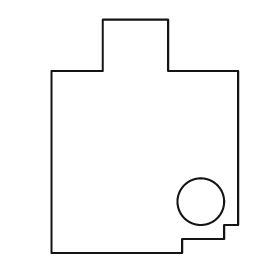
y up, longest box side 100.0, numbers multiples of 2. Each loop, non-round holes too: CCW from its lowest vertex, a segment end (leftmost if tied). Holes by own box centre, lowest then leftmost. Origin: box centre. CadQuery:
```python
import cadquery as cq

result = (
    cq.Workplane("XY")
    .moveTo(-40.0, -50.0)
    .lineTo(16.0, -50.0)
    .lineTo(16.0, -44.0)
    .lineTo(34.0, -44.0)
    .lineTo(34.0, -38.0)
    .lineTo(40.0, -38.0)
    .lineTo(40.0, 28.0)
    .lineTo(10.0, 28.0)
    .lineTo(10.0, 50.0)
    .lineTo(-18.0, 50.0)
    .lineTo(-18.0, 28.0)
    .lineTo(-40.0, 28.0)
    .close()
    .moveTo(24.0, -28.0)
    .circle(10.0)
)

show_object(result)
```